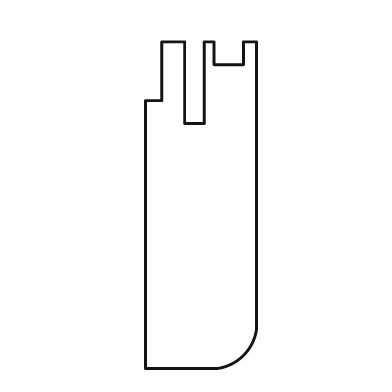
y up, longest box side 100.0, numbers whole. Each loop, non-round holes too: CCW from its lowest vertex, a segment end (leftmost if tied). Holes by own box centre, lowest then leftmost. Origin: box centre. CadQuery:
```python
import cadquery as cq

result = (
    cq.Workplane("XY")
    .moveTo(-17.0, -50.0)
    .lineTo(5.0, -50.0)
    .threePointArc((13.0, -46.0), (17.0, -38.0))
    .lineTo(17.0, 50.0)
    .lineTo(13.0, 50.0)
    .lineTo(13.0, 43.0)
    .lineTo(4.0, 43.0)
    .lineTo(4.0, 50.0)
    .lineTo(1.0, 50.0)
    .lineTo(1.0, 25.0)
    .lineTo(-5.0, 25.0)
    .lineTo(-5.0, 50.0)
    .lineTo(-12.0, 50.0)
    .lineTo(-12.0, 32.0)
    .lineTo(-17.0, 32.0)
    .close()
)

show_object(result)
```